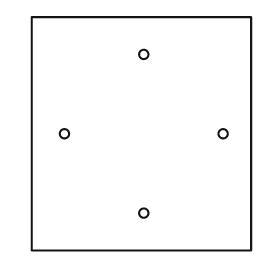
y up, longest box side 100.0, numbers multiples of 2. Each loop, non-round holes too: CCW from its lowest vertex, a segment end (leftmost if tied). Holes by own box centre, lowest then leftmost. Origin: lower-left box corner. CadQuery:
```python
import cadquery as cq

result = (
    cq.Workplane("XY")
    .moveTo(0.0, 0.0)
    .lineTo(94.0, 0.0)
    .lineTo(94.0, 100.0)
    .lineTo(0.0, 100.0)
    .close()
    .moveTo(48.0, 16.0)
    .circle(2.0)
    .moveTo(14.0, 50.0)
    .circle(2.0)
    .moveTo(82.0, 50.0)
    .circle(2.0)
    .moveTo(48.0, 84.0)
    .circle(2.0)
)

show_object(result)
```